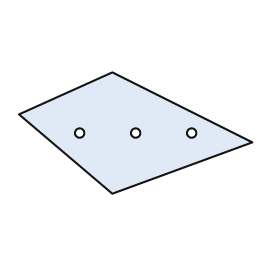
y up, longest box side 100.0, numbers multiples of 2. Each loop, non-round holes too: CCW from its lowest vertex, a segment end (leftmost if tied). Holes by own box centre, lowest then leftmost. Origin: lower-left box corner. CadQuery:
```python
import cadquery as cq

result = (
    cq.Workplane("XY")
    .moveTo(40.0, 0.0)
    .lineTo(100.0, 22.0)
    .lineTo(40.0, 52.0)
    .lineTo(0.0, 34.0)
    .close()
    .moveTo(26.0, 26.0)
    .circle(2.0)
    .moveTo(50.0, 26.0)
    .circle(2.0)
    .moveTo(74.0, 26.0)
    .circle(2.0)
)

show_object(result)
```